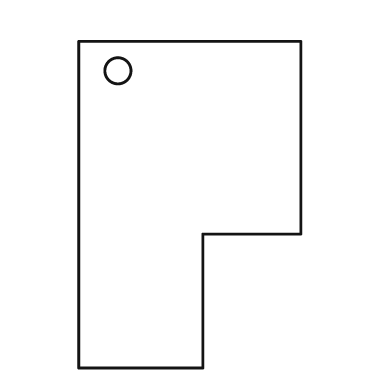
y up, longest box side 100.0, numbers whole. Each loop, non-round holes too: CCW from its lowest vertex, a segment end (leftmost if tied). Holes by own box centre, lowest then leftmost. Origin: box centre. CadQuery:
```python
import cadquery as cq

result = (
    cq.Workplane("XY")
    .moveTo(-34.0, -50.0)
    .lineTo(4.0, -50.0)
    .lineTo(4.0, -9.0)
    .lineTo(34.0, -9.0)
    .lineTo(34.0, 50.0)
    .lineTo(-34.0, 50.0)
    .close()
    .moveTo(-22.0, 41.0)
    .circle(4.0)
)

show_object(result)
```